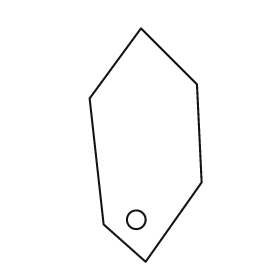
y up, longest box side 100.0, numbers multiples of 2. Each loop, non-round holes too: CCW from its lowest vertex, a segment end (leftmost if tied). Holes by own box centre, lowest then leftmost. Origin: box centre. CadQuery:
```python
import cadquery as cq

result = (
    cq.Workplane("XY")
    .moveTo(0.0, -50.0)
    .lineTo(24.0, -16.0)
    .lineTo(22.0, 26.0)
    .lineTo(-2.0, 50.0)
    .lineTo(-24.0, 20.0)
    .lineTo(-18.0, -34.0)
    .close()
    .moveTo(-4.0, -32.0)
    .circle(4.0)
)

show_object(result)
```